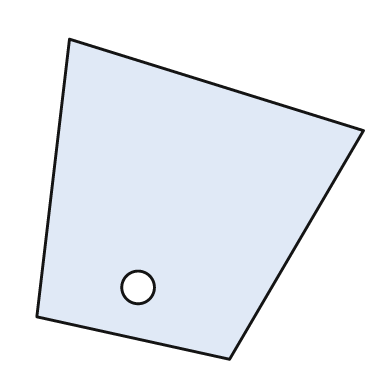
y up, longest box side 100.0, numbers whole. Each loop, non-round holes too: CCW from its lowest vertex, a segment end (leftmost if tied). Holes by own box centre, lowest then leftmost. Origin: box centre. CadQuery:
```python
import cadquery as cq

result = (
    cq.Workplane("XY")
    .moveTo(9.0, -49.0)
    .lineTo(50.0, 21.0)
    .lineTo(-40.0, 49.0)
    .lineTo(-50.0, -36.0)
    .close()
    .moveTo(-19.0, -27.0)
    .circle(5.0)
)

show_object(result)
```